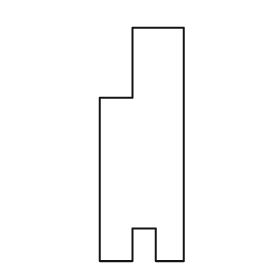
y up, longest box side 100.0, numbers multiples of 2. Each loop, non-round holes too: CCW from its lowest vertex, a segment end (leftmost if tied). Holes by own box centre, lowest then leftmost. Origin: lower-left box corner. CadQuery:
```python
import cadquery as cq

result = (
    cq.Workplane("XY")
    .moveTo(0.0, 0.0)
    .lineTo(14.0, 0.0)
    .lineTo(14.0, 14.0)
    .lineTo(24.0, 14.0)
    .lineTo(24.0, 0.0)
    .lineTo(36.0, 0.0)
    .lineTo(36.0, 100.0)
    .lineTo(14.0, 100.0)
    .lineTo(14.0, 70.0)
    .lineTo(0.0, 70.0)
    .close()
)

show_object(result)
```